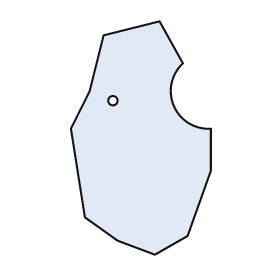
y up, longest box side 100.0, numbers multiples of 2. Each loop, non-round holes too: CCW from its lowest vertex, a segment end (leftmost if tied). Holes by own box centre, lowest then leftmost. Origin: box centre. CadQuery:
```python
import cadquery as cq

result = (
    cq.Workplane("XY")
    .moveTo(6.0, -50.0)
    .lineTo(20.0, -42.0)
    .lineTo(30.0, -14.0)
    .lineTo(30.0, 4.0)
    .threePointArc((14.0, 14.0), (18.0, 32.0))
    .lineTo(8.0, 50.0)
    .lineTo(-16.0, 44.0)
    .lineTo(-22.0, 20.0)
    .lineTo(-30.0, 4.0)
    .lineTo(-24.0, -34.0)
    .lineTo(-10.0, -44.0)
    .close()
    .moveTo(-12.0, 16.0)
    .circle(2.0)
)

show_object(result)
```